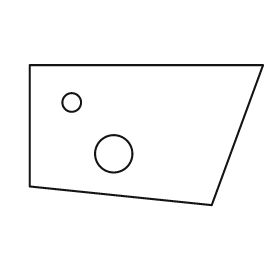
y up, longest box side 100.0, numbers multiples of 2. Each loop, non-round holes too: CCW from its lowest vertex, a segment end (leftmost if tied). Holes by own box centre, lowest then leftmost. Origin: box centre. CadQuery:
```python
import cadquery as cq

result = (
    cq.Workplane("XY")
    .moveTo(28.0, -30.0)
    .lineTo(50.0, 30.0)
    .lineTo(-50.0, 30.0)
    .lineTo(-50.0, -22.0)
    .close()
    .moveTo(-14.0, -8.0)
    .circle(8.0)
    .moveTo(-32.0, 14.0)
    .circle(4.0)
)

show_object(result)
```